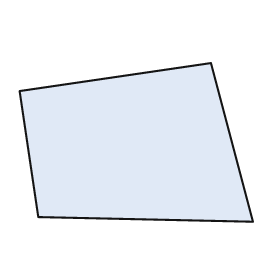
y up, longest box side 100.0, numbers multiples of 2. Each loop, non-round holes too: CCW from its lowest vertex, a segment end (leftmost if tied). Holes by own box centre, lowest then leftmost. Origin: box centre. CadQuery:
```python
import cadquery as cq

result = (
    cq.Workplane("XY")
    .moveTo(50.0, -34.0)
    .lineTo(32.0, 34.0)
    .lineTo(-50.0, 22.0)
    .lineTo(-42.0, -32.0)
    .close()
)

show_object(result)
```